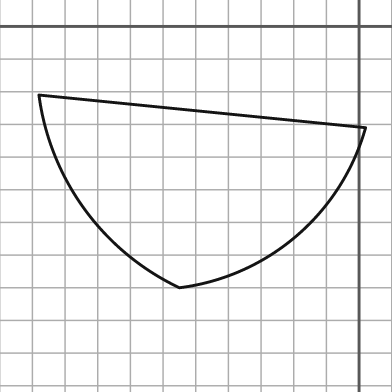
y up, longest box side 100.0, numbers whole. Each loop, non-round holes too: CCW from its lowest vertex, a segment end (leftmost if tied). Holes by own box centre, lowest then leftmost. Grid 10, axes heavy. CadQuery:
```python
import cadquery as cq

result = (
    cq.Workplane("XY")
    .moveTo(-55.0, -80.0)
    .threePointArc((-19.0, -64.0), (2.0, -31.0))
    .lineTo(-98.0, -21.0)
    .threePointArc((-84.0, -56.0), (-55.0, -80.0))
    .close()
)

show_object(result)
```